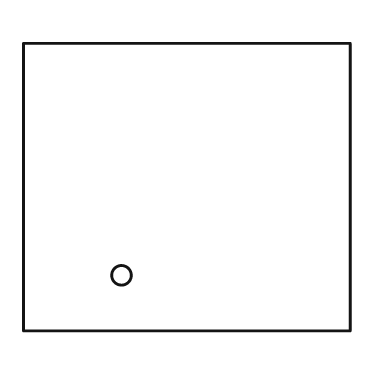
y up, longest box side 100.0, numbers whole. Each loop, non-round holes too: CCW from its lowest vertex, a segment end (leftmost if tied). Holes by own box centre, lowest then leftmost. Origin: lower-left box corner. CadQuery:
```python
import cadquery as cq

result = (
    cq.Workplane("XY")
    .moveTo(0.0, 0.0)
    .lineTo(100.0, 0.0)
    .lineTo(100.0, 88.0)
    .lineTo(0.0, 88.0)
    .close()
    .moveTo(30.0, 17.0)
    .circle(3.0)
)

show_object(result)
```